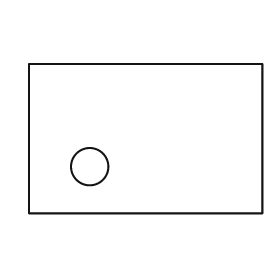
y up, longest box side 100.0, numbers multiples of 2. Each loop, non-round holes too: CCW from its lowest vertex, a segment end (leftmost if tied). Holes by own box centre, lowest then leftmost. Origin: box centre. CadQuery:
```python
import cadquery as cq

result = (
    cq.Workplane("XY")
    .moveTo(-50.0, -32.0)
    .lineTo(50.0, -32.0)
    .lineTo(50.0, 32.0)
    .lineTo(-50.0, 32.0)
    .close()
    .moveTo(-24.0, -12.0)
    .circle(8.0)
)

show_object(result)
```